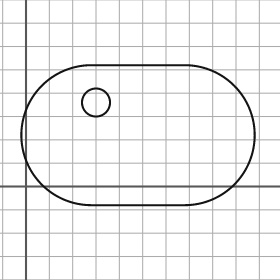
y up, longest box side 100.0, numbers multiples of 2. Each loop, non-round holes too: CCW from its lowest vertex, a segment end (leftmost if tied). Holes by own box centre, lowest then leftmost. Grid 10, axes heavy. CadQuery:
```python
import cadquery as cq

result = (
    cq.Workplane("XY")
    .moveTo(28.0, -8.0)
    .lineTo(68.0, -8.0)
    .threePointArc((98.0, 22.0), (68.0, 52.0))
    .lineTo(28.0, 52.0)
    .threePointArc((-2.0, 22.0), (28.0, -8.0))
    .close()
    .moveTo(30.0, 36.0)
    .circle(6.0)
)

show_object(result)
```